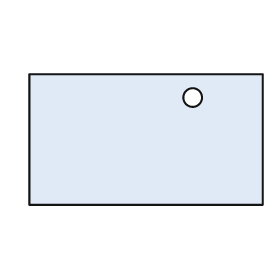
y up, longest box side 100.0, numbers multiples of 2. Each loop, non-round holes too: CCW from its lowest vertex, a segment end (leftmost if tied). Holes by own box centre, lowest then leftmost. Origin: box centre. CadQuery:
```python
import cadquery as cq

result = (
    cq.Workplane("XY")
    .moveTo(-50.0, -28.0)
    .lineTo(50.0, -28.0)
    .lineTo(50.0, 28.0)
    .lineTo(-50.0, 28.0)
    .close()
    .moveTo(20.0, 18.0)
    .circle(4.0)
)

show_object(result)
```